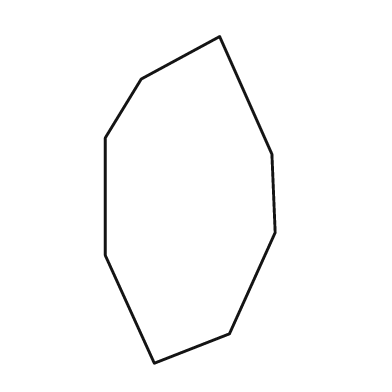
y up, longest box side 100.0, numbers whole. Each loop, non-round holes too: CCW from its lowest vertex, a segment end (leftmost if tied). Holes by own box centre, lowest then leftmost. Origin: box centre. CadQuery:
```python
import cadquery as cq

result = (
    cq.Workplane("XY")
    .moveTo(-11.0, -50.0)
    .lineTo(12.0, -41.0)
    .lineTo(26.0, -10.0)
    .lineTo(25.0, 14.0)
    .lineTo(9.0, 50.0)
    .lineTo(-15.0, 37.0)
    .lineTo(-26.0, 19.0)
    .lineTo(-26.0, -17.0)
    .close()
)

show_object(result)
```